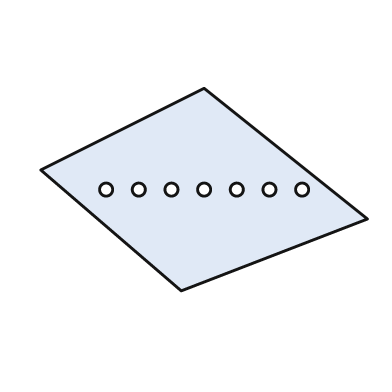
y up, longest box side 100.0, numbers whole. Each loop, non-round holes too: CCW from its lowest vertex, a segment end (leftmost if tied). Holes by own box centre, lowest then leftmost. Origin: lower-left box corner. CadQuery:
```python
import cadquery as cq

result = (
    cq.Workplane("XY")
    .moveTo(43.0, 0.0)
    .lineTo(100.0, 22.0)
    .lineTo(50.0, 62.0)
    .lineTo(0.0, 37.0)
    .close()
    .moveTo(20.0, 31.0)
    .circle(2.0)
    .moveTo(30.0, 31.0)
    .circle(2.0)
    .moveTo(40.0, 31.0)
    .circle(2.0)
    .moveTo(50.0, 31.0)
    .circle(2.0)
    .moveTo(60.0, 31.0)
    .circle(2.0)
    .moveTo(70.0, 31.0)
    .circle(2.0)
    .moveTo(80.0, 31.0)
    .circle(2.0)
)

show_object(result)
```